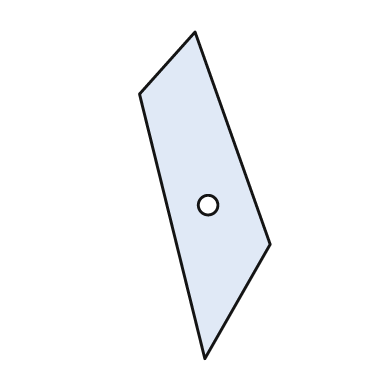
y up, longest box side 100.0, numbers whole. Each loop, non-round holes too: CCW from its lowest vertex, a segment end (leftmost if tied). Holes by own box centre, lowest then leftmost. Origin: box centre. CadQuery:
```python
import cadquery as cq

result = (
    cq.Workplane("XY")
    .moveTo(0.0, -50.0)
    .lineTo(20.0, -15.0)
    .lineTo(-3.0, 50.0)
    .lineTo(-20.0, 31.0)
    .close()
    .moveTo(1.0, -3.0)
    .circle(3.0)
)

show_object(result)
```